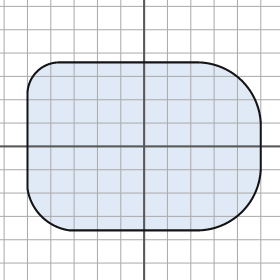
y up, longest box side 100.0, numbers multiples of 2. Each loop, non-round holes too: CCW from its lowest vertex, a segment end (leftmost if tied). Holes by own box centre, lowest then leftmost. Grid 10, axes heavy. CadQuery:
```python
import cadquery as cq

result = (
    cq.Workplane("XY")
    .moveTo(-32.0, -36.0)
    .lineTo(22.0, -36.0)
    .threePointArc((42.0, -28.0), (50.0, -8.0))
    .lineTo(50.0, 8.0)
    .threePointArc((42.0, 28.0), (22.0, 36.0))
    .lineTo(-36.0, 36.0)
    .threePointArc((-46.0, 32.0), (-50.0, 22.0))
    .lineTo(-50.0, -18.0)
    .threePointArc((-44.0, -30.0), (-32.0, -36.0))
    .close()
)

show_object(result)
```